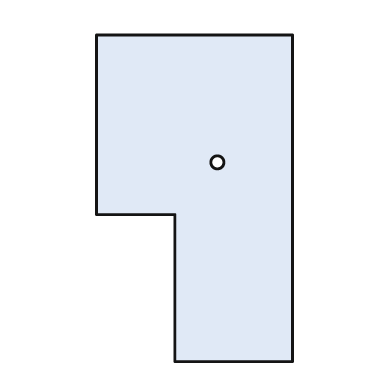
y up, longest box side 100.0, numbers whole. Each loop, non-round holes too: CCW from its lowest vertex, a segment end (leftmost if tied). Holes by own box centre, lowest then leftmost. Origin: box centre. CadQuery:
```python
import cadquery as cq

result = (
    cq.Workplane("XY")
    .moveTo(-6.0, -50.0)
    .lineTo(30.0, -50.0)
    .lineTo(30.0, 50.0)
    .lineTo(-30.0, 50.0)
    .lineTo(-30.0, -5.0)
    .lineTo(-6.0, -5.0)
    .close()
    .moveTo(7.0, 11.0)
    .circle(2.0)
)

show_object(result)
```